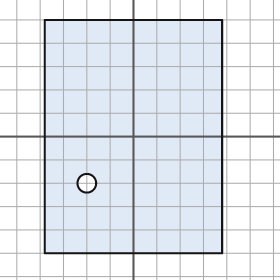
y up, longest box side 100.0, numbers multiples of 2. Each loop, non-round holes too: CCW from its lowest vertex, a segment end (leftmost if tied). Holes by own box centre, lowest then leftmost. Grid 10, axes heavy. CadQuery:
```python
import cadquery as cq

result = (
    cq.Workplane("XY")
    .moveTo(-38.0, -50.0)
    .lineTo(38.0, -50.0)
    .lineTo(38.0, 50.0)
    .lineTo(-38.0, 50.0)
    .close()
    .moveTo(-20.0, -20.0)
    .circle(4.0)
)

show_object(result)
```